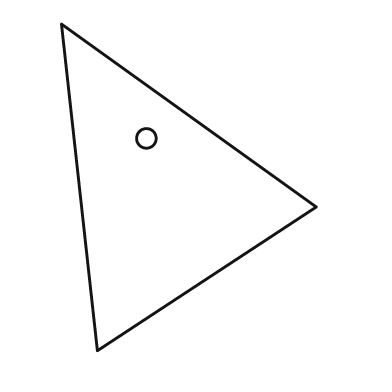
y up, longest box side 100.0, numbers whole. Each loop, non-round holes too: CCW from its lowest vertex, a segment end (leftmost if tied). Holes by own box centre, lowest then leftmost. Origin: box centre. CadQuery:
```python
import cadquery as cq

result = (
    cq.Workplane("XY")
    .moveTo(-28.0, -50.0)
    .lineTo(39.0, -6.0)
    .lineTo(-39.0, 50.0)
    .close()
    .moveTo(-13.0, 15.0)
    .circle(3.0)
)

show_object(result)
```